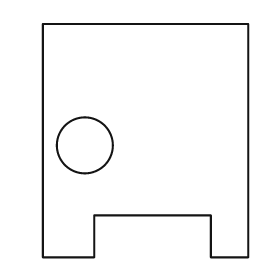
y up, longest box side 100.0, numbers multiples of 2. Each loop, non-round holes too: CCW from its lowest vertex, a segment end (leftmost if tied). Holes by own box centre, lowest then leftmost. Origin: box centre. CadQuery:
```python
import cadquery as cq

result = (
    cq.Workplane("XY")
    .moveTo(-44.0, -50.0)
    .lineTo(-22.0, -50.0)
    .lineTo(-22.0, -32.0)
    .lineTo(28.0, -32.0)
    .lineTo(28.0, -50.0)
    .lineTo(44.0, -50.0)
    .lineTo(44.0, 50.0)
    .lineTo(-44.0, 50.0)
    .close()
    .moveTo(-26.0, -2.0)
    .circle(12.0)
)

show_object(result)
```